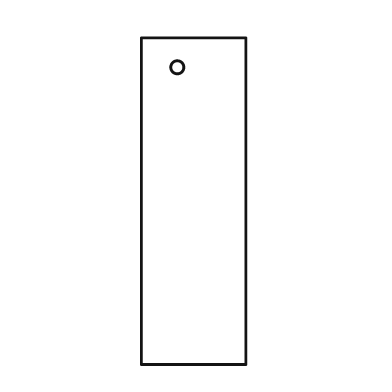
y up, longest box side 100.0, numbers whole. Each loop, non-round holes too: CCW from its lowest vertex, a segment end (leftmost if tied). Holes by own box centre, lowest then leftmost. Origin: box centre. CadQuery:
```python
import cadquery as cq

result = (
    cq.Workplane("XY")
    .moveTo(-16.0, -50.0)
    .lineTo(16.0, -50.0)
    .lineTo(16.0, 50.0)
    .lineTo(-16.0, 50.0)
    .close()
    .moveTo(-5.0, 41.0)
    .circle(2.0)
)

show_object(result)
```